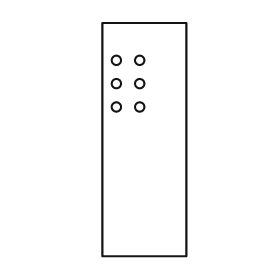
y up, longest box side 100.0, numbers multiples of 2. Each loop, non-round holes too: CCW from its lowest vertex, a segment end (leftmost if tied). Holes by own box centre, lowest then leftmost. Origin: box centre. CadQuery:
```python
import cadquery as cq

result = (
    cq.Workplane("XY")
    .moveTo(-18.0, -50.0)
    .lineTo(18.0, -50.0)
    .lineTo(18.0, 50.0)
    .lineTo(-18.0, 50.0)
    .close()
    .moveTo(-12.0, 14.0)
    .circle(2.0)
    .moveTo(-2.0, 14.0)
    .circle(2.0)
    .moveTo(-12.0, 24.0)
    .circle(2.0)
    .moveTo(-2.0, 24.0)
    .circle(2.0)
    .moveTo(-12.0, 34.0)
    .circle(2.0)
    .moveTo(-2.0, 34.0)
    .circle(2.0)
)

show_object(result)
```